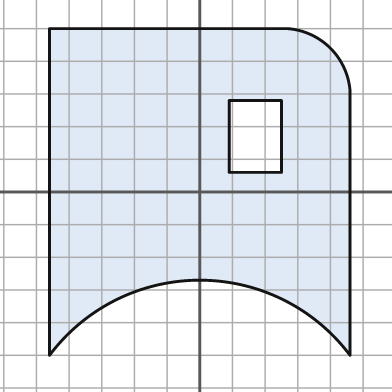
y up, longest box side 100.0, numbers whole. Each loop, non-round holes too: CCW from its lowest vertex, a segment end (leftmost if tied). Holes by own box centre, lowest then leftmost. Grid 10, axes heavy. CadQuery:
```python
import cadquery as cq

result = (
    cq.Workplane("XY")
    .moveTo(-46.0, -50.0)
    .threePointArc((0.0, -27.0), (46.0, -50.0))
    .lineTo(46.0, 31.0)
    .threePointArc((40.0, 44.0), (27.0, 50.0))
    .lineTo(-46.0, 50.0)
    .close()
    .moveTo(9.0, 6.0)
    .lineTo(25.0, 6.0)
    .lineTo(25.0, 28.0)
    .lineTo(9.0, 28.0)
    .close()
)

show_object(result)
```